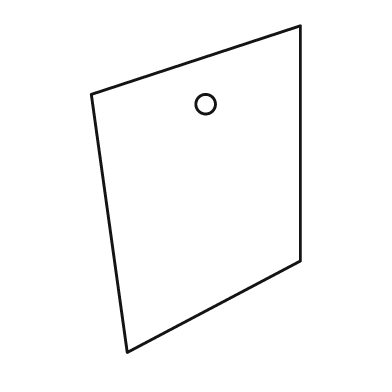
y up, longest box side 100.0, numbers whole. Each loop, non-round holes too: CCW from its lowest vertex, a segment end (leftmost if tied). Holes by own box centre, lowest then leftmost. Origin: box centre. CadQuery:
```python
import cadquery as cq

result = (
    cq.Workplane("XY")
    .moveTo(-21.0, -50.0)
    .lineTo(32.0, -22.0)
    .lineTo(32.0, 50.0)
    .lineTo(-32.0, 29.0)
    .close()
    .moveTo(3.0, 26.0)
    .circle(3.0)
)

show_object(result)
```